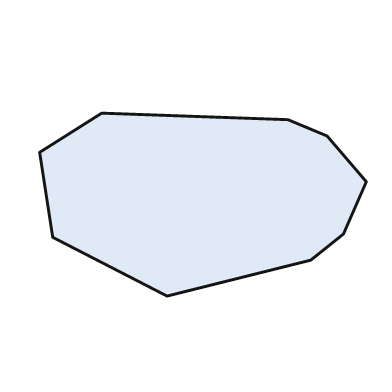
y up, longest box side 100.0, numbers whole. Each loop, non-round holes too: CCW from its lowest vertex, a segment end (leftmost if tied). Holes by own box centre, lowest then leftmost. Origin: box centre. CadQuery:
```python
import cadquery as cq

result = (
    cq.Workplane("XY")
    .moveTo(-11.0, -28.0)
    .lineTo(33.0, -17.0)
    .lineTo(43.0, -9.0)
    .lineTo(50.0, 7.0)
    .lineTo(38.0, 21.0)
    .lineTo(26.0, 26.0)
    .lineTo(-31.0, 28.0)
    .lineTo(-50.0, 16.0)
    .lineTo(-46.0, -10.0)
    .close()
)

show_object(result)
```